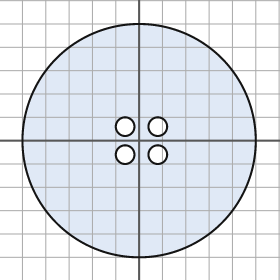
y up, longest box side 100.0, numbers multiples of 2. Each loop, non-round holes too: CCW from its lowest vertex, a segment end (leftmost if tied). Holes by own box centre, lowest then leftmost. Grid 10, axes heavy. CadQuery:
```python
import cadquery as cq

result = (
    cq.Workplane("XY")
    .moveTo(0.0, 0.0)
    .circle(50.0)
    .moveTo(-6.0, -6.0)
    .circle(4.0)
    .moveTo(8.0, -6.0)
    .circle(4.0)
    .moveTo(-6.0, 6.0)
    .circle(4.0)
    .moveTo(8.0, 6.0)
    .circle(4.0)
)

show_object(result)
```